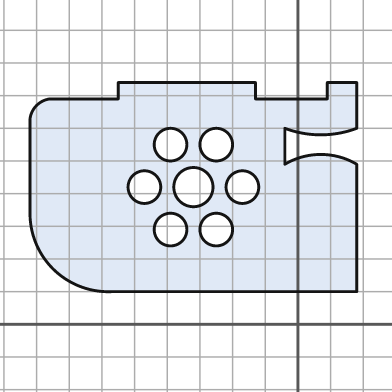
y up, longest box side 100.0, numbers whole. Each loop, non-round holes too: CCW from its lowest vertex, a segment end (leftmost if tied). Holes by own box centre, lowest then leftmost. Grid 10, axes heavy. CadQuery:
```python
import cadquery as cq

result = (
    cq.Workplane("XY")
    .moveTo(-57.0, 10.0)
    .lineTo(18.0, 10.0)
    .lineTo(18.0, 49.0)
    .threePointArc((7.0, 52.0), (-4.0, 49.0))
    .lineTo(-4.0, 60.0)
    .threePointArc((7.0, 58.0), (18.0, 60.0))
    .lineTo(18.0, 74.0)
    .lineTo(9.0, 74.0)
    .lineTo(9.0, 69.0)
    .lineTo(-13.0, 69.0)
    .lineTo(-13.0, 74.0)
    .lineTo(-55.0, 74.0)
    .lineTo(-55.0, 69.0)
    .lineTo(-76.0, 69.0)
    .threePointArc((-80.0, 67.0), (-82.0, 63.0))
    .lineTo(-82.0, 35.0)
    .threePointArc((-75.0, 17.0), (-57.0, 10.0))
    .close()
    .moveTo(-39.0, 29.0)
    .circle(5.0)
    .moveTo(-25.0, 29.0)
    .circle(5.0)
    .moveTo(-47.0, 42.0)
    .circle(5.0)
    .moveTo(-32.0, 42.0)
    .circle(6.0)
    .moveTo(-17.0, 42.0)
    .circle(5.0)
    .moveTo(-39.0, 55.0)
    .circle(5.0)
    .moveTo(-25.0, 55.0)
    .circle(5.0)
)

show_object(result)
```